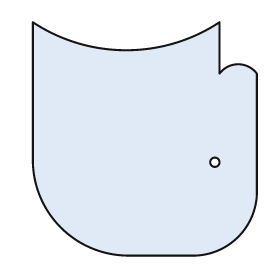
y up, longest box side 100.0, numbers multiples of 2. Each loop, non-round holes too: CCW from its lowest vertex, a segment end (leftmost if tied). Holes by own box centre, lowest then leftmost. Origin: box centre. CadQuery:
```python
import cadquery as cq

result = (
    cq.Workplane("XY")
    .moveTo(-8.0, -50.0)
    .lineTo(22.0, -50.0)
    .threePointArc((40.0, -42.0), (48.0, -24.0))
    .lineTo(48.0, 28.0)
    .threePointArc((40.0, 32.0), (32.0, 28.0))
    .lineTo(32.0, 50.0)
    .threePointArc((-8.0, 38.0), (-48.0, 50.0))
    .lineTo(-48.0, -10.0)
    .threePointArc((-36.0, -38.0), (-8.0, -50.0))
    .close()
    .moveTo(30.0, -10.0)
    .circle(2.0)
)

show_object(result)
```